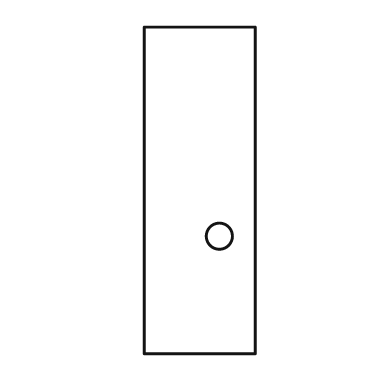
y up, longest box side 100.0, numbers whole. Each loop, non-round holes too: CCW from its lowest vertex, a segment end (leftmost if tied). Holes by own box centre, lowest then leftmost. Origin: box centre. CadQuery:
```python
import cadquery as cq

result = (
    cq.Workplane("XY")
    .moveTo(-17.0, -50.0)
    .lineTo(17.0, -50.0)
    .lineTo(17.0, 50.0)
    .lineTo(-17.0, 50.0)
    .close()
    .moveTo(6.0, -14.0)
    .circle(4.0)
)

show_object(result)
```